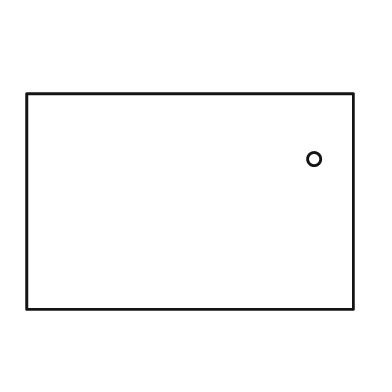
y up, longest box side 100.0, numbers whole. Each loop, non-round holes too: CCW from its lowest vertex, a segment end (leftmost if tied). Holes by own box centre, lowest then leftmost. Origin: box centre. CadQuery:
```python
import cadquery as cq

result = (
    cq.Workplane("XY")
    .moveTo(-50.0, -33.0)
    .lineTo(50.0, -33.0)
    .lineTo(50.0, 33.0)
    .lineTo(-50.0, 33.0)
    .close()
    .moveTo(38.0, 13.0)
    .circle(2.0)
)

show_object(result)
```